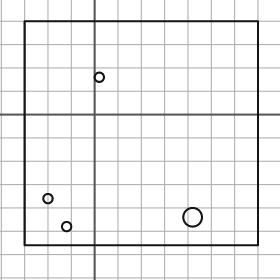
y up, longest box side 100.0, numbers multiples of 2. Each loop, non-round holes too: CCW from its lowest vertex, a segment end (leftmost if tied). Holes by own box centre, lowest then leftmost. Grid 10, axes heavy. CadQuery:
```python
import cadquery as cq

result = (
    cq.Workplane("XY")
    .moveTo(-30.0, -56.0)
    .lineTo(70.0, -56.0)
    .lineTo(70.0, 40.0)
    .lineTo(-30.0, 40.0)
    .close()
    .moveTo(-12.0, -48.0)
    .circle(2.0)
    .moveTo(42.0, -44.0)
    .circle(4.0)
    .moveTo(-20.0, -36.0)
    .circle(2.0)
    .moveTo(2.0, 16.0)
    .circle(2.0)
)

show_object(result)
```